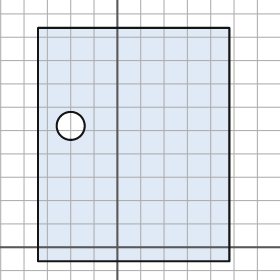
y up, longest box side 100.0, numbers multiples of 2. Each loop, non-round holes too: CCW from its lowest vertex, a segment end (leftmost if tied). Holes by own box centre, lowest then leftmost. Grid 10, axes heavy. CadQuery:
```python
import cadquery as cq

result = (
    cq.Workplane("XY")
    .moveTo(-34.0, -6.0)
    .lineTo(48.0, -6.0)
    .lineTo(48.0, 94.0)
    .lineTo(-34.0, 94.0)
    .close()
    .moveTo(-20.0, 52.0)
    .circle(6.0)
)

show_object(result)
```